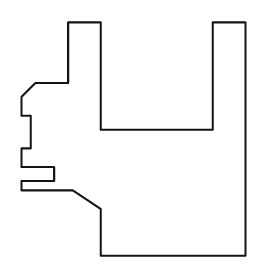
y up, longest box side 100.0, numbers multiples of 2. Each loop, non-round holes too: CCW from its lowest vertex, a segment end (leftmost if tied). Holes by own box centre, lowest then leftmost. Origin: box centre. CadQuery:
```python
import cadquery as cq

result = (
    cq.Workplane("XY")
    .moveTo(-14.0, -50.0)
    .lineTo(48.0, -50.0)
    .lineTo(48.0, 50.0)
    .lineTo(34.0, 50.0)
    .lineTo(34.0, 4.0)
    .lineTo(-14.0, 4.0)
    .lineTo(-14.0, 50.0)
    .lineTo(-28.0, 50.0)
    .lineTo(-28.0, 24.0)
    .lineTo(-42.0, 24.0)
    .lineTo(-48.0, 18.0)
    .lineTo(-48.0, 10.0)
    .lineTo(-44.0, 10.0)
    .lineTo(-44.0, -4.0)
    .lineTo(-48.0, -4.0)
    .lineTo(-48.0, -12.0)
    .lineTo(-34.0, -12.0)
    .lineTo(-34.0, -18.0)
    .lineTo(-48.0, -18.0)
    .lineTo(-48.0, -22.0)
    .lineTo(-26.0, -22.0)
    .lineTo(-14.0, -30.0)
    .close()
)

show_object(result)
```